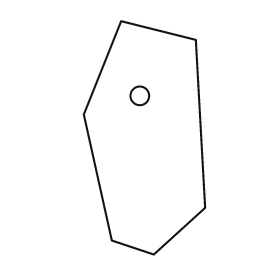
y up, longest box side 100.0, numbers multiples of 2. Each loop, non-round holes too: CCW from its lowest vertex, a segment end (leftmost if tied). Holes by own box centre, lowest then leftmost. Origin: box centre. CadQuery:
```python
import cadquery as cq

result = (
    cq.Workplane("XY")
    .moveTo(4.0, -50.0)
    .lineTo(26.0, -30.0)
    .lineTo(22.0, 42.0)
    .lineTo(-10.0, 50.0)
    .lineTo(-26.0, 10.0)
    .lineTo(-14.0, -44.0)
    .close()
    .moveTo(-2.0, 18.0)
    .circle(4.0)
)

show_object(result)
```